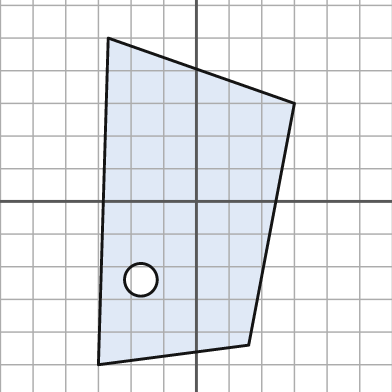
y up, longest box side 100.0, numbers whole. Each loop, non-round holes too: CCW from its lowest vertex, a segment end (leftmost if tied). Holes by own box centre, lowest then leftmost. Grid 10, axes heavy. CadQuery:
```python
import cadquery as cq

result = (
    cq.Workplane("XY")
    .moveTo(-30.0, -50.0)
    .lineTo(16.0, -44.0)
    .lineTo(30.0, 30.0)
    .lineTo(-27.0, 50.0)
    .close()
    .moveTo(-17.0, -24.0)
    .circle(5.0)
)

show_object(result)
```